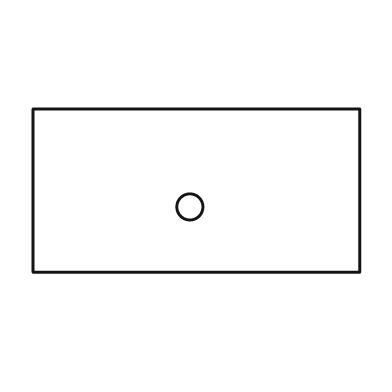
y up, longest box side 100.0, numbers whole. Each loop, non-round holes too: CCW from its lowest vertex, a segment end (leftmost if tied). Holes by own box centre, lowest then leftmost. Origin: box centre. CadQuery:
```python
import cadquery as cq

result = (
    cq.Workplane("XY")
    .moveTo(-50.0, -25.0)
    .lineTo(50.0, -25.0)
    .lineTo(50.0, 25.0)
    .lineTo(-50.0, 25.0)
    .close()
    .moveTo(-2.0, -5.0)
    .circle(4.0)
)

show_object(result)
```